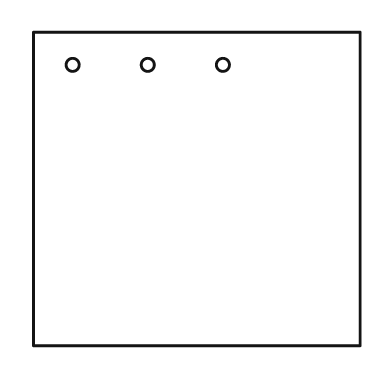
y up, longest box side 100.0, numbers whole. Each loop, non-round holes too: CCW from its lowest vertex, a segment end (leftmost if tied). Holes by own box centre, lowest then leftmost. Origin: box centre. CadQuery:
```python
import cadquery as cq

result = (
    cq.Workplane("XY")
    .moveTo(-50.0, -48.0)
    .lineTo(50.0, -48.0)
    .lineTo(50.0, 48.0)
    .lineTo(-50.0, 48.0)
    .close()
    .moveTo(-38.0, 38.0)
    .circle(2.0)
    .moveTo(-15.0, 38.0)
    .circle(2.0)
    .moveTo(8.0, 38.0)
    .circle(2.0)
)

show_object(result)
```